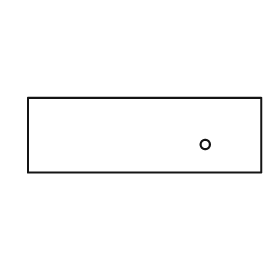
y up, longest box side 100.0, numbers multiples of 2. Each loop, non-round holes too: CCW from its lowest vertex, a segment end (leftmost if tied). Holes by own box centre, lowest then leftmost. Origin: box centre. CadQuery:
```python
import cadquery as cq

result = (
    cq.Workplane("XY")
    .moveTo(-50.0, -16.0)
    .lineTo(50.0, -16.0)
    .lineTo(50.0, 16.0)
    .lineTo(-50.0, 16.0)
    .close()
    .moveTo(26.0, -4.0)
    .circle(2.0)
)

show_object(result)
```